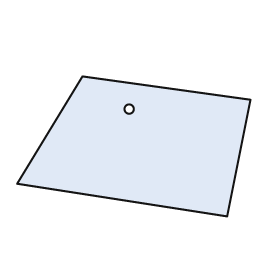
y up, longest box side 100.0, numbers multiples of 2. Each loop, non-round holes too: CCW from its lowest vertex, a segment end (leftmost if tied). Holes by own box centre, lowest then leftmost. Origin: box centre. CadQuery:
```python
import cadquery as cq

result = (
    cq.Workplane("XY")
    .moveTo(40.0, -30.0)
    .lineTo(50.0, 20.0)
    .lineTo(-22.0, 30.0)
    .lineTo(-50.0, -16.0)
    .close()
    .moveTo(-2.0, 16.0)
    .circle(2.0)
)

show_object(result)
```